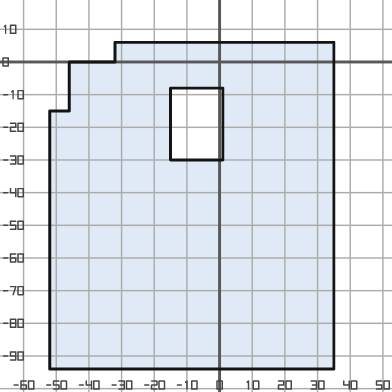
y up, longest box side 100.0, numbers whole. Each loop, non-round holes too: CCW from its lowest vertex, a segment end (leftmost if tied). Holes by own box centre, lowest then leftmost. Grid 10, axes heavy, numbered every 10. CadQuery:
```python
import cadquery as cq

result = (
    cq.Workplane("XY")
    .moveTo(-52.0, -94.0)
    .lineTo(35.0, -94.0)
    .lineTo(35.0, 6.0)
    .lineTo(-32.0, 6.0)
    .lineTo(-32.0, 0.0)
    .lineTo(-46.0, 0.0)
    .lineTo(-46.0, -15.0)
    .lineTo(-52.0, -15.0)
    .close()
    .moveTo(-15.0, -30.0)
    .lineTo(1.0, -30.0)
    .lineTo(1.0, -8.0)
    .lineTo(-15.0, -8.0)
    .close()
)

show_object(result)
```